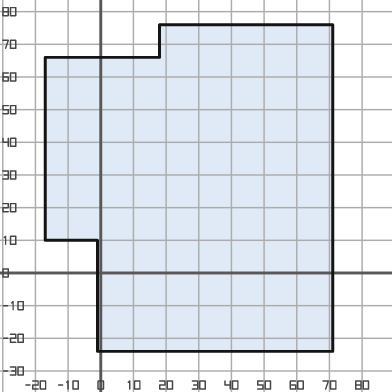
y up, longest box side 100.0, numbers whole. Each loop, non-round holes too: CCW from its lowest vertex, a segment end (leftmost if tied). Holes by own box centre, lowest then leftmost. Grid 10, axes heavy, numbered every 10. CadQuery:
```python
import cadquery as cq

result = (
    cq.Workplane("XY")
    .moveTo(-1.0, -24.0)
    .lineTo(71.0, -24.0)
    .lineTo(71.0, 76.0)
    .lineTo(18.0, 76.0)
    .lineTo(18.0, 66.0)
    .lineTo(-17.0, 66.0)
    .lineTo(-17.0, 10.0)
    .lineTo(-1.0, 10.0)
    .close()
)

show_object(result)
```